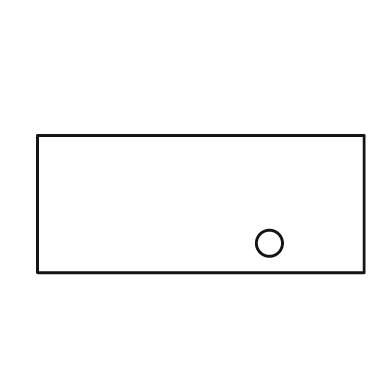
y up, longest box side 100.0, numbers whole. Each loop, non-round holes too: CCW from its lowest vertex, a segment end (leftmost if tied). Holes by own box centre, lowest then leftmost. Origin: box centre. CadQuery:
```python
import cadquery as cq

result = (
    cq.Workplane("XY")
    .moveTo(-50.0, -21.0)
    .lineTo(50.0, -21.0)
    .lineTo(50.0, 21.0)
    .lineTo(-50.0, 21.0)
    .close()
    .moveTo(21.0, -12.0)
    .circle(4.0)
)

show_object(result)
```